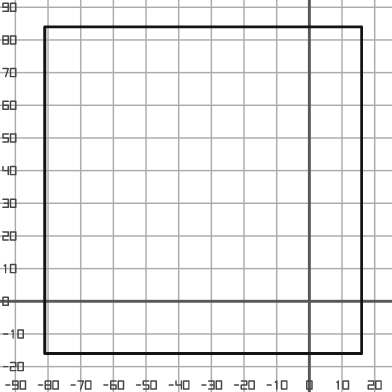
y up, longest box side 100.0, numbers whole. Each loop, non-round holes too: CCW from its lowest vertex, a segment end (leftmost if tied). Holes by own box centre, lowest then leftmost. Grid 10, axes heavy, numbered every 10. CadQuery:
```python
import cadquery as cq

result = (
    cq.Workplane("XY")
    .moveTo(-81.0, -16.0)
    .lineTo(16.0, -16.0)
    .lineTo(16.0, 84.0)
    .lineTo(-81.0, 84.0)
    .close()
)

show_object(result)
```